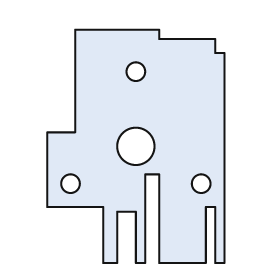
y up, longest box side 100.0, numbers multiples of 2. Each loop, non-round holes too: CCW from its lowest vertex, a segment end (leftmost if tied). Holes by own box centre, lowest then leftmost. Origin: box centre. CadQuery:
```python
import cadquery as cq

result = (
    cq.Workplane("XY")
    .moveTo(-14.0, -50.0)
    .lineTo(-8.0, -50.0)
    .lineTo(-8.0, -28.0)
    .lineTo(0.0, -28.0)
    .lineTo(0.0, -50.0)
    .lineTo(4.0, -50.0)
    .lineTo(4.0, -12.0)
    .lineTo(10.0, -12.0)
    .lineTo(10.0, -50.0)
    .lineTo(30.0, -50.0)
    .lineTo(30.0, -26.0)
    .lineTo(34.0, -26.0)
    .lineTo(34.0, -50.0)
    .lineTo(38.0, -50.0)
    .lineTo(38.0, 40.0)
    .lineTo(34.0, 40.0)
    .lineTo(34.0, 46.0)
    .lineTo(10.0, 46.0)
    .lineTo(10.0, 50.0)
    .lineTo(-26.0, 50.0)
    .lineTo(-26.0, 6.0)
    .lineTo(-38.0, 6.0)
    .lineTo(-38.0, -26.0)
    .lineTo(-14.0, -26.0)
    .close()
    .moveTo(-28.0, -16.0)
    .circle(4.0)
    .moveTo(28.0, -16.0)
    .circle(4.0)
    .moveTo(0.0, 0.0)
    .circle(8.0)
    .moveTo(0.0, 32.0)
    .circle(4.0)
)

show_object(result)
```